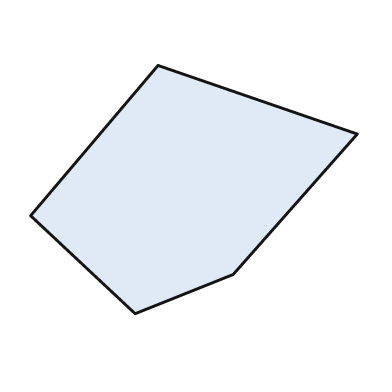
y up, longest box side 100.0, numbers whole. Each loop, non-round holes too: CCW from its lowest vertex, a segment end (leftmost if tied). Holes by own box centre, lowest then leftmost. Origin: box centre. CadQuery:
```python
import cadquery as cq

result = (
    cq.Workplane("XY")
    .moveTo(-18.0, -38.0)
    .lineTo(12.0, -26.0)
    .lineTo(50.0, 17.0)
    .lineTo(-11.0, 38.0)
    .lineTo(-50.0, -8.0)
    .close()
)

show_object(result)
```